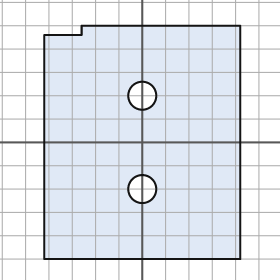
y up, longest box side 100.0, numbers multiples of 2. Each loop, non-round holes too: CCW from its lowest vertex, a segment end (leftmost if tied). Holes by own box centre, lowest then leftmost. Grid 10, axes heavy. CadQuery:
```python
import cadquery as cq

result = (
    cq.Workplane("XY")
    .moveTo(-42.0, -50.0)
    .lineTo(42.0, -50.0)
    .lineTo(42.0, 50.0)
    .lineTo(-26.0, 50.0)
    .lineTo(-26.0, 46.0)
    .lineTo(-42.0, 46.0)
    .close()
    .moveTo(0.0, -20.0)
    .circle(6.0)
    .moveTo(0.0, 20.0)
    .circle(6.0)
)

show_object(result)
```